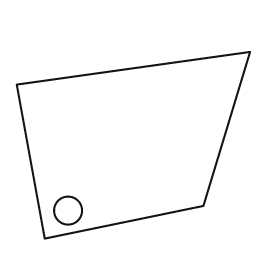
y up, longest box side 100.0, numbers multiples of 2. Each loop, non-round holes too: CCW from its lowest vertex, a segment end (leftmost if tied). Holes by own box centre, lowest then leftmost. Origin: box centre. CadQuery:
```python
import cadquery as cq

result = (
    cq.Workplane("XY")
    .moveTo(-38.0, -40.0)
    .lineTo(30.0, -26.0)
    .lineTo(50.0, 40.0)
    .lineTo(-50.0, 26.0)
    .close()
    .moveTo(-28.0, -28.0)
    .circle(6.0)
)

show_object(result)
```